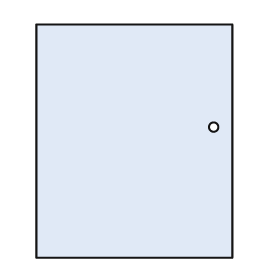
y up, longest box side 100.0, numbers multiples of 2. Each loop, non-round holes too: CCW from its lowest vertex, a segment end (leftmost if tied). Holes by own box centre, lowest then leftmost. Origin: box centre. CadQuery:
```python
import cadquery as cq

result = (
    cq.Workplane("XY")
    .moveTo(-42.0, -50.0)
    .lineTo(42.0, -50.0)
    .lineTo(42.0, 50.0)
    .lineTo(-42.0, 50.0)
    .close()
    .moveTo(34.0, 6.0)
    .circle(2.0)
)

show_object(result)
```